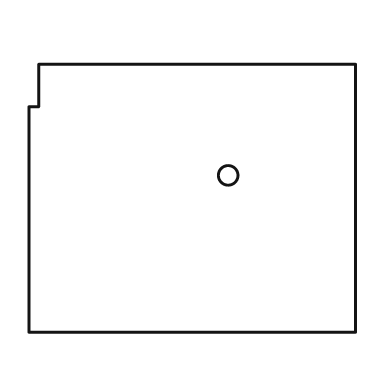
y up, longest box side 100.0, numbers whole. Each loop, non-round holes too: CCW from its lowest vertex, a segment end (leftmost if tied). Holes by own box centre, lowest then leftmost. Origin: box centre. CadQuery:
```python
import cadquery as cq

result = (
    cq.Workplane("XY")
    .moveTo(-50.0, -41.0)
    .lineTo(50.0, -41.0)
    .lineTo(50.0, 41.0)
    .lineTo(-47.0, 41.0)
    .lineTo(-47.0, 28.0)
    .lineTo(-50.0, 28.0)
    .close()
    .moveTo(11.0, 7.0)
    .circle(3.0)
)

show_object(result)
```